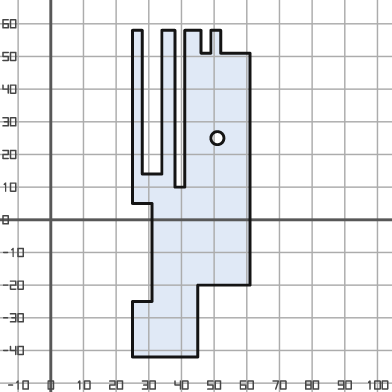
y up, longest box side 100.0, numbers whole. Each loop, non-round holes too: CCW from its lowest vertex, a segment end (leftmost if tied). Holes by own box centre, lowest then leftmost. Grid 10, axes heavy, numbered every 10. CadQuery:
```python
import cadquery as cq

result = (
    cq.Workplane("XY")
    .moveTo(25.0, -42.0)
    .lineTo(45.0, -42.0)
    .lineTo(45.0, -20.0)
    .lineTo(61.0, -20.0)
    .lineTo(61.0, 51.0)
    .lineTo(52.0, 51.0)
    .lineTo(52.0, 58.0)
    .lineTo(49.0, 58.0)
    .lineTo(49.0, 51.0)
    .lineTo(46.0, 51.0)
    .lineTo(46.0, 58.0)
    .lineTo(41.0, 58.0)
    .lineTo(41.0, 10.0)
    .lineTo(38.0, 10.0)
    .lineTo(38.0, 58.0)
    .lineTo(34.0, 58.0)
    .lineTo(34.0, 14.0)
    .lineTo(28.0, 14.0)
    .lineTo(28.0, 58.0)
    .lineTo(25.0, 58.0)
    .lineTo(25.0, 5.0)
    .lineTo(31.0, 5.0)
    .lineTo(31.0, -25.0)
    .lineTo(25.0, -25.0)
    .close()
    .moveTo(51.0, 25.0)
    .circle(2.0)
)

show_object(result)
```